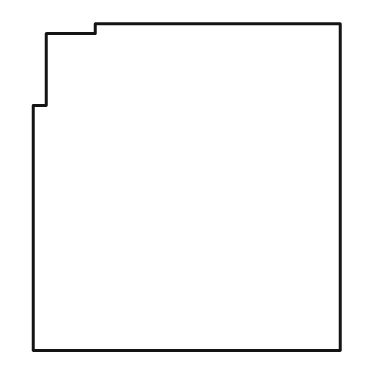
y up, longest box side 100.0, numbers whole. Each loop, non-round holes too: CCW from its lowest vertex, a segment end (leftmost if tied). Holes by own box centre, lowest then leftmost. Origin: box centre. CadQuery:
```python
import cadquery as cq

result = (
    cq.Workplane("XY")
    .moveTo(-47.0, -50.0)
    .lineTo(47.0, -50.0)
    .lineTo(47.0, 50.0)
    .lineTo(-28.0, 50.0)
    .lineTo(-28.0, 47.0)
    .lineTo(-43.0, 47.0)
    .lineTo(-43.0, 25.0)
    .lineTo(-47.0, 25.0)
    .close()
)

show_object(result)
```